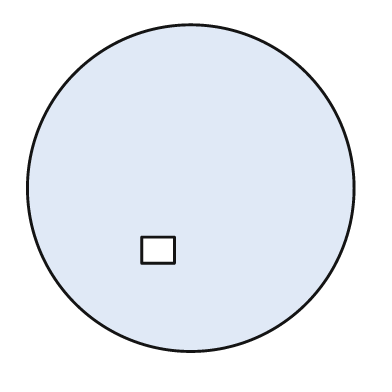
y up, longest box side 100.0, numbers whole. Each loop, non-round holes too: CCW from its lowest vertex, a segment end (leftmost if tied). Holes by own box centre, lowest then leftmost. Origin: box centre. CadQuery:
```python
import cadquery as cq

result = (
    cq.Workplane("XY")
    .moveTo(0.0, 0.0)
    .circle(50.0)
    .moveTo(-15.0, -23.0)
    .lineTo(-5.0, -23.0)
    .lineTo(-5.0, -15.0)
    .lineTo(-15.0, -15.0)
    .close()
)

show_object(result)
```